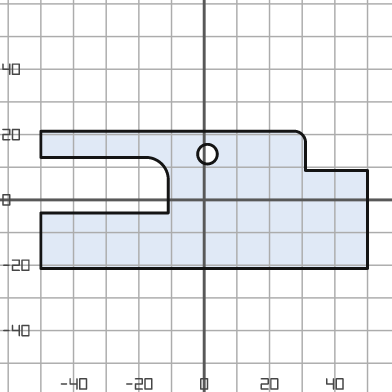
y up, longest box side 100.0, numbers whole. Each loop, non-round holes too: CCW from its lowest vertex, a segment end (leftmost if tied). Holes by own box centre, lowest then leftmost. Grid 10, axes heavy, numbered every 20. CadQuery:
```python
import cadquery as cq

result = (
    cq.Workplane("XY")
    .moveTo(-50.0, -21.0)
    .lineTo(50.0, -21.0)
    .lineTo(50.0, 9.0)
    .lineTo(31.0, 9.0)
    .lineTo(31.0, 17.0)
    .threePointArc((30.0, 20.0), (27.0, 21.0))
    .lineTo(-50.0, 21.0)
    .lineTo(-50.0, 13.0)
    .lineTo(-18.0, 13.0)
    .threePointArc((-13.0, 11.0), (-11.0, 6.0))
    .lineTo(-11.0, -4.0)
    .lineTo(-50.0, -4.0)
    .close()
    .moveTo(1.0, 14.0)
    .circle(3.0)
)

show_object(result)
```